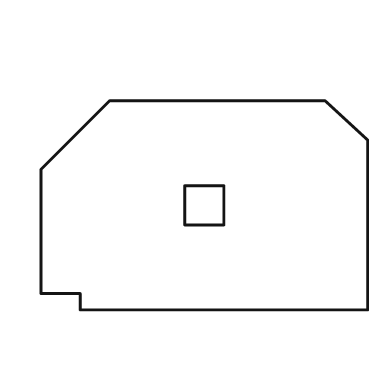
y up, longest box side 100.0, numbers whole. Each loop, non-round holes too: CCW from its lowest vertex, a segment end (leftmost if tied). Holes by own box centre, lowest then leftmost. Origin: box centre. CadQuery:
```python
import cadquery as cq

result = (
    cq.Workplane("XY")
    .moveTo(-38.0, -32.0)
    .lineTo(50.0, -32.0)
    .lineTo(50.0, 20.0)
    .lineTo(37.0, 32.0)
    .lineTo(-29.0, 32.0)
    .lineTo(-50.0, 11.0)
    .lineTo(-50.0, -27.0)
    .lineTo(-38.0, -27.0)
    .close()
    .moveTo(-6.0, -6.0)
    .lineTo(6.0, -6.0)
    .lineTo(6.0, 6.0)
    .lineTo(-6.0, 6.0)
    .close()
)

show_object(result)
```